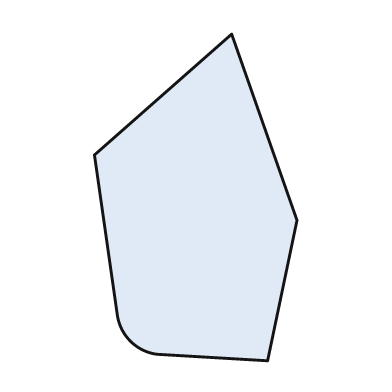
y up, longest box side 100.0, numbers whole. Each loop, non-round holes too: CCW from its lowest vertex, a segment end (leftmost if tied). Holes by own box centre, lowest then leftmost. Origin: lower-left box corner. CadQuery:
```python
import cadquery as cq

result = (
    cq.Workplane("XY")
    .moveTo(53.0, 0.0)
    .lineTo(62.0, 43.0)
    .lineTo(42.0, 100.0)
    .lineTo(0.0, 63.0)
    .lineTo(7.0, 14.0)
    .threePointArc((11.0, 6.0), (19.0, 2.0))
    .close()
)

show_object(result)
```